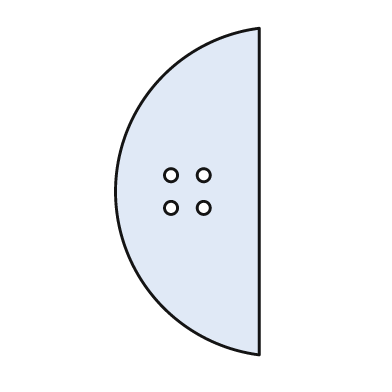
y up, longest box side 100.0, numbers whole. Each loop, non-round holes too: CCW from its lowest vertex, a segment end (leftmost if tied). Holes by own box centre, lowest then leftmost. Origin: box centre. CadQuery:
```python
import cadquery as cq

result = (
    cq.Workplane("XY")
    .moveTo(22.0, -50.0)
    .lineTo(22.0, 50.0)
    .threePointArc((-22.0, 0.0), (22.0, -50.0))
    .close()
    .moveTo(-5.0, -5.0)
    .circle(2.0)
    .moveTo(5.0, -5.0)
    .circle(2.0)
    .moveTo(-5.0, 5.0)
    .circle(2.0)
    .moveTo(5.0, 5.0)
    .circle(2.0)
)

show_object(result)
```